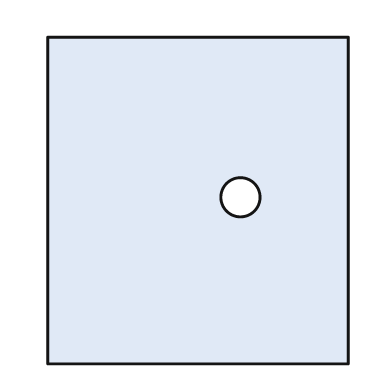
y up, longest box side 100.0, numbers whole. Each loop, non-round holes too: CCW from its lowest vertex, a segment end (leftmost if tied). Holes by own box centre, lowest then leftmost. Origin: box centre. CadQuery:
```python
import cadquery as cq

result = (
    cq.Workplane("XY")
    .moveTo(-46.0, -50.0)
    .lineTo(46.0, -50.0)
    .lineTo(46.0, 50.0)
    .lineTo(-46.0, 50.0)
    .close()
    .moveTo(13.0, 1.0)
    .circle(6.0)
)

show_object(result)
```